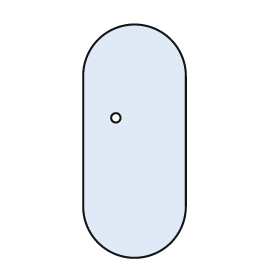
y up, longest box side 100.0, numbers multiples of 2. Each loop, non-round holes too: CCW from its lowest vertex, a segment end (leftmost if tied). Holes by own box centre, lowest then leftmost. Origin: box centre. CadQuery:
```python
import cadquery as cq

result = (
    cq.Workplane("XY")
    .moveTo(-22.0, -28.0)
    .threePointArc((0.0, -50.0), (22.0, -28.0))
    .lineTo(22.0, 28.0)
    .threePointArc((0.0, 50.0), (-22.0, 28.0))
    .close()
    .moveTo(-8.0, 10.0)
    .circle(2.0)
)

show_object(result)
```